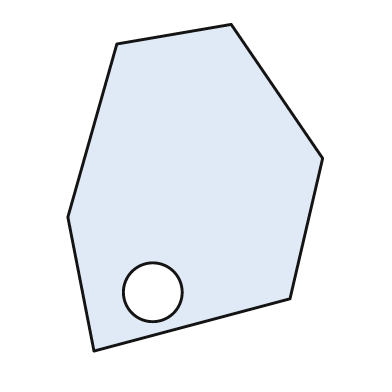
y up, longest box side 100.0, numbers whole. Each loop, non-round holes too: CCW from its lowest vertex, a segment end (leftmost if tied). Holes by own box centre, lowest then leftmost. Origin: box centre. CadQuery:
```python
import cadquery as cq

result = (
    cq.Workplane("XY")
    .moveTo(-31.0, -50.0)
    .lineTo(29.0, -34.0)
    .lineTo(39.0, 9.0)
    .lineTo(11.0, 50.0)
    .lineTo(-24.0, 44.0)
    .lineTo(-39.0, -9.0)
    .close()
    .moveTo(-13.0, -32.0)
    .circle(9.0)
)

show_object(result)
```